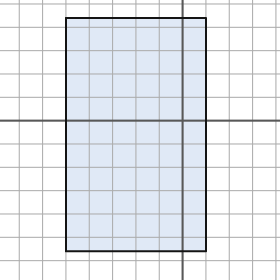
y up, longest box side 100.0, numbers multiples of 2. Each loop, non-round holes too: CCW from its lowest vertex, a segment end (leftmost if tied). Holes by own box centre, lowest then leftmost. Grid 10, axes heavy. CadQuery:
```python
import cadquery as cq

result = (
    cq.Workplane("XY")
    .moveTo(-50.0, -56.0)
    .lineTo(10.0, -56.0)
    .lineTo(10.0, 44.0)
    .lineTo(-50.0, 44.0)
    .close()
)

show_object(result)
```